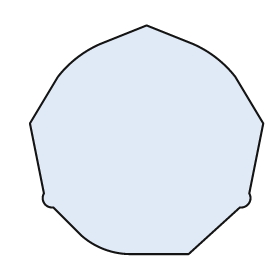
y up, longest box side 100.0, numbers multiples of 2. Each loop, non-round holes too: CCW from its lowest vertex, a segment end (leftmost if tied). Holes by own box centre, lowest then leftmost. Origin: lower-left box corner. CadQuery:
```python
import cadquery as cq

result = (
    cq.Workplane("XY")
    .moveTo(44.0, 0.0)
    .lineTo(68.0, 0.0)
    .lineTo(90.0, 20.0)
    .threePointArc((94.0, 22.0), (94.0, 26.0))
    .lineTo(100.0, 56.0)
    .lineTo(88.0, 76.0)
    .threePointArc((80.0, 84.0), (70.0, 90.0))
    .lineTo(50.0, 98.0)
    .lineTo(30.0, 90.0)
    .threePointArc((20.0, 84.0), (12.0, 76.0))
    .lineTo(0.0, 56.0)
    .lineTo(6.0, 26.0)
    .threePointArc((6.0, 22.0), (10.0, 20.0))
    .lineTo(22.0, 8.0)
    .threePointArc((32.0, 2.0), (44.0, 0.0))
    .close()
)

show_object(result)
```